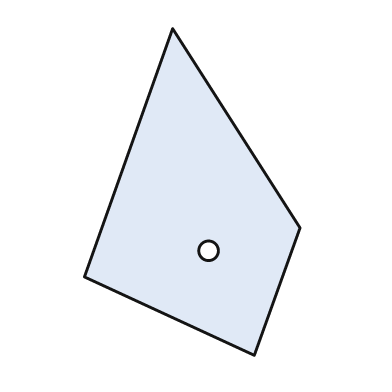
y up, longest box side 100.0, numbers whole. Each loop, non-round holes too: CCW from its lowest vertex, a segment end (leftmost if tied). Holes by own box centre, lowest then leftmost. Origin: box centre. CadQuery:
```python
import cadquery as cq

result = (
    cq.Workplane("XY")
    .moveTo(19.0, -50.0)
    .lineTo(33.0, -11.0)
    .lineTo(-6.0, 50.0)
    .lineTo(-33.0, -26.0)
    .close()
    .moveTo(5.0, -18.0)
    .circle(3.0)
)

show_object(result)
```